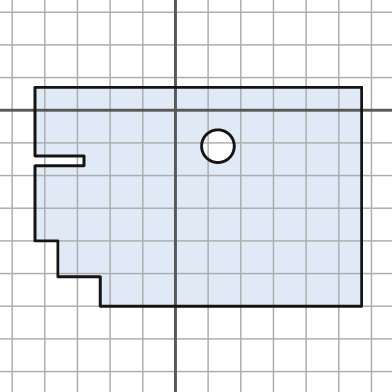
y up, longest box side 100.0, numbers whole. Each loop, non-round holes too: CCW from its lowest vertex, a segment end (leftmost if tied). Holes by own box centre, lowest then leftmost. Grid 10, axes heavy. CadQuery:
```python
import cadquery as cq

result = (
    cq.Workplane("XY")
    .moveTo(-23.0, -60.0)
    .lineTo(57.0, -60.0)
    .lineTo(57.0, 7.0)
    .lineTo(-43.0, 7.0)
    .lineTo(-43.0, -14.0)
    .lineTo(-28.0, -14.0)
    .lineTo(-28.0, -17.0)
    .lineTo(-43.0, -17.0)
    .lineTo(-43.0, -40.0)
    .lineTo(-36.0, -40.0)
    .lineTo(-36.0, -51.0)
    .lineTo(-23.0, -51.0)
    .close()
    .moveTo(13.0, -11.0)
    .circle(5.0)
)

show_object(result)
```